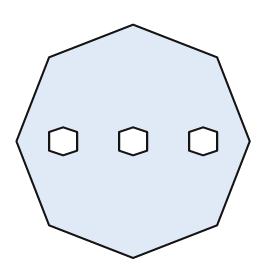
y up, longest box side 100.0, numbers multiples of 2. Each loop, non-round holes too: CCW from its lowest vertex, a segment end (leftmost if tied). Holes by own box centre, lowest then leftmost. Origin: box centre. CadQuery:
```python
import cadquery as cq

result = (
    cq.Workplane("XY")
    .moveTo(0.0, -50.0)
    .lineTo(36.0, -36.0)
    .lineTo(50.0, 0.0)
    .lineTo(36.0, 36.0)
    .lineTo(0.0, 50.0)
    .lineTo(-36.0, 36.0)
    .lineTo(-50.0, 0.0)
    .lineTo(-36.0, -36.0)
    .close()
    .moveTo(-30.0, -6.0)
    .lineTo(-24.0, -4.0)
    .lineTo(-24.0, 4.0)
    .lineTo(-30.0, 6.0)
    .lineTo(-36.0, 4.0)
    .lineTo(-36.0, -4.0)
    .close()
    .moveTo(0.0, -6.0)
    .lineTo(6.0, -4.0)
    .lineTo(6.0, 4.0)
    .lineTo(0.0, 6.0)
    .lineTo(-6.0, 4.0)
    .lineTo(-6.0, -4.0)
    .close()
    .moveTo(30.0, -6.0)
    .lineTo(36.0, -4.0)
    .lineTo(36.0, 4.0)
    .lineTo(30.0, 6.0)
    .lineTo(24.0, 4.0)
    .lineTo(24.0, -4.0)
    .close()
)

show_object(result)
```